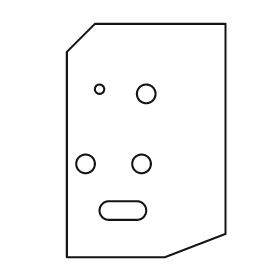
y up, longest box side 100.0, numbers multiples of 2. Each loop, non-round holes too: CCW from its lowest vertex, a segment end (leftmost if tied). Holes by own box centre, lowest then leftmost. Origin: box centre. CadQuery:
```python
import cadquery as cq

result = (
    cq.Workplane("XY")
    .moveTo(-34.0, -50.0)
    .lineTo(8.0, -50.0)
    .lineTo(34.0, -40.0)
    .lineTo(34.0, 50.0)
    .lineTo(-22.0, 50.0)
    .lineTo(-34.0, 38.0)
    .close()
    .moveTo(-16.0, -34.0)
    .lineTo(-4.0, -34.0)
    .threePointArc((0.0, -30.0), (-4.0, -26.0))
    .lineTo(-16.0, -26.0)
    .threePointArc((-20.0, -30.0), (-16.0, -34.0))
    .close()
    .moveTo(-26.0, -10.0)
    .circle(4.0)
    .moveTo(-2.0, -10.0)
    .circle(4.0)
    .moveTo(0.0, 20.0)
    .circle(4.0)
    .moveTo(-20.0, 22.0)
    .circle(2.0)
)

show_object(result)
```